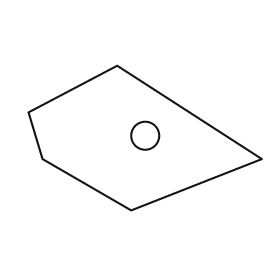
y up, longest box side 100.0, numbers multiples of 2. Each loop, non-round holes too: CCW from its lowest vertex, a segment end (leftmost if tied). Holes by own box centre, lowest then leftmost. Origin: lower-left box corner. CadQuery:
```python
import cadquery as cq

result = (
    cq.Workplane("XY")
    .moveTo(44.0, 0.0)
    .lineTo(100.0, 22.0)
    .lineTo(38.0, 62.0)
    .lineTo(0.0, 42.0)
    .lineTo(6.0, 22.0)
    .close()
    .moveTo(50.0, 32.0)
    .circle(6.0)
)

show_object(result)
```